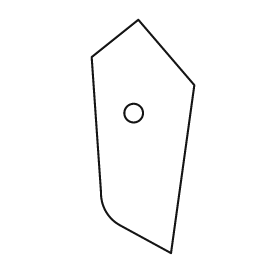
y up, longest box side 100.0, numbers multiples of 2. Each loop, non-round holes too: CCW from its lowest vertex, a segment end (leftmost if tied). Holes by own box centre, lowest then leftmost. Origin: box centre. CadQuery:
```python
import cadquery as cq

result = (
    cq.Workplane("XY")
    .moveTo(12.0, -50.0)
    .lineTo(22.0, 22.0)
    .lineTo(-2.0, 50.0)
    .lineTo(-22.0, 34.0)
    .lineTo(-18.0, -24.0)
    .threePointArc((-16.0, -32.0), (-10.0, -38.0))
    .close()
    .moveTo(-4.0, 10.0)
    .circle(4.0)
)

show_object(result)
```